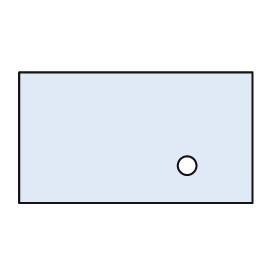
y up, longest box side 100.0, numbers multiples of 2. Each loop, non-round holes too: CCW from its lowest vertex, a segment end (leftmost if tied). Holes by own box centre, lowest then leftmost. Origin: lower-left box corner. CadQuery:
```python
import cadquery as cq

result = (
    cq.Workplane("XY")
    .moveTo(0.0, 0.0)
    .lineTo(100.0, 0.0)
    .lineTo(100.0, 56.0)
    .lineTo(0.0, 56.0)
    .close()
    .moveTo(72.0, 16.0)
    .circle(4.0)
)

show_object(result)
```